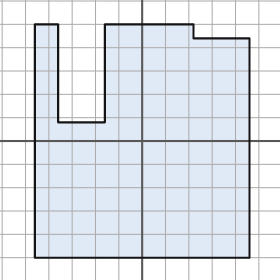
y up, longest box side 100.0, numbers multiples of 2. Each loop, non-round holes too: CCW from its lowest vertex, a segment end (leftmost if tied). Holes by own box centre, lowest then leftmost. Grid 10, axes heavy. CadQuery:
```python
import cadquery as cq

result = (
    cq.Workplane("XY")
    .moveTo(-46.0, -50.0)
    .lineTo(46.0, -50.0)
    .lineTo(46.0, 44.0)
    .lineTo(22.0, 44.0)
    .lineTo(22.0, 50.0)
    .lineTo(-16.0, 50.0)
    .lineTo(-16.0, 8.0)
    .lineTo(-36.0, 8.0)
    .lineTo(-36.0, 50.0)
    .lineTo(-46.0, 50.0)
    .close()
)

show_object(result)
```